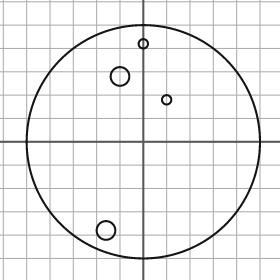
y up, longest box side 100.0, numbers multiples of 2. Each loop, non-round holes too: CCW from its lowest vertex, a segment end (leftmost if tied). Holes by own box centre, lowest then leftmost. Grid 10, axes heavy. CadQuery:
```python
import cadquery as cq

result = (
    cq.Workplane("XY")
    .moveTo(0.0, 0.0)
    .circle(50.0)
    .moveTo(-16.0, -38.0)
    .circle(4.0)
    .moveTo(10.0, 18.0)
    .circle(2.0)
    .moveTo(-10.0, 28.0)
    .circle(4.0)
    .moveTo(0.0, 42.0)
    .circle(2.0)
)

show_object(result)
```